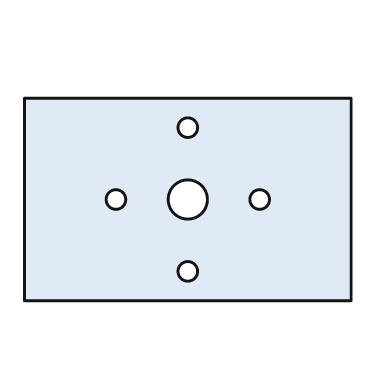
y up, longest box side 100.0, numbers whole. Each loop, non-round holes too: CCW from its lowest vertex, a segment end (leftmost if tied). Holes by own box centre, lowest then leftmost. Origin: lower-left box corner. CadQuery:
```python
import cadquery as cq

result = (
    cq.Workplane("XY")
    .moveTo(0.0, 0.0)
    .lineTo(100.0, 0.0)
    .lineTo(100.0, 62.0)
    .lineTo(0.0, 62.0)
    .close()
    .moveTo(50.0, 9.0)
    .circle(3.0)
    .moveTo(28.0, 31.0)
    .circle(3.0)
    .moveTo(50.0, 31.0)
    .circle(6.0)
    .moveTo(72.0, 31.0)
    .circle(3.0)
    .moveTo(50.0, 53.0)
    .circle(3.0)
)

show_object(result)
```